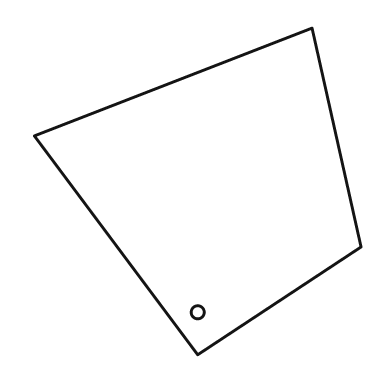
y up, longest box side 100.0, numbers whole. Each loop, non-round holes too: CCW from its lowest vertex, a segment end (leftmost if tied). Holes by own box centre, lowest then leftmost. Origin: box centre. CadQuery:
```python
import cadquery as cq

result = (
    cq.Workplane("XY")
    .moveTo(0.0, -50.0)
    .lineTo(50.0, -17.0)
    .lineTo(35.0, 50.0)
    .lineTo(-50.0, 17.0)
    .close()
    .moveTo(0.0, -37.0)
    .circle(2.0)
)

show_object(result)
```